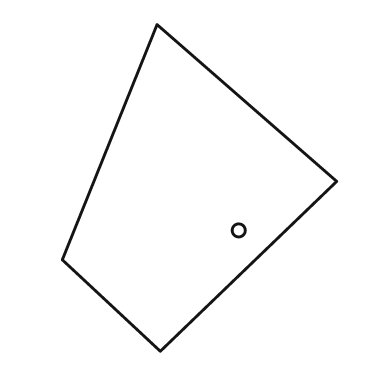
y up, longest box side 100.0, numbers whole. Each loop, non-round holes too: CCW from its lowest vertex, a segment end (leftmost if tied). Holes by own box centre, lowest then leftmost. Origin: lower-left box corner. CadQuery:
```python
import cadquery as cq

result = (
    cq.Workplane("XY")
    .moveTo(30.0, 0.0)
    .lineTo(84.0, 52.0)
    .lineTo(29.0, 100.0)
    .lineTo(0.0, 28.0)
    .close()
    .moveTo(54.0, 37.0)
    .circle(2.0)
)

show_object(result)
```